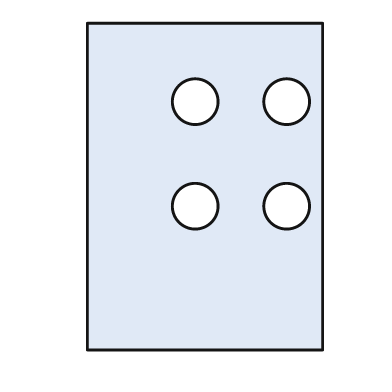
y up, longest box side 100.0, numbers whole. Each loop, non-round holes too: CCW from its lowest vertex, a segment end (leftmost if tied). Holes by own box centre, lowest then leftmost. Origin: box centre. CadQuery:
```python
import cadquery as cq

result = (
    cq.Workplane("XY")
    .moveTo(-36.0, -50.0)
    .lineTo(36.0, -50.0)
    .lineTo(36.0, 50.0)
    .lineTo(-36.0, 50.0)
    .close()
    .moveTo(-3.0, -6.0)
    .circle(7.0)
    .moveTo(25.0, -6.0)
    .circle(7.0)
    .moveTo(-3.0, 26.0)
    .circle(7.0)
    .moveTo(25.0, 26.0)
    .circle(7.0)
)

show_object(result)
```